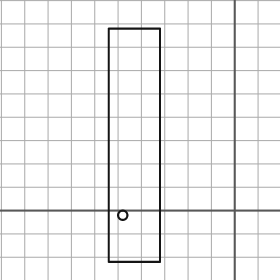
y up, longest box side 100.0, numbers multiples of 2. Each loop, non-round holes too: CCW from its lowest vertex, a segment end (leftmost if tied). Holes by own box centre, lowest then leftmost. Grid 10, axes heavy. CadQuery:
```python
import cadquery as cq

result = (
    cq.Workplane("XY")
    .moveTo(-54.0, -22.0)
    .lineTo(-32.0, -22.0)
    .lineTo(-32.0, 78.0)
    .lineTo(-54.0, 78.0)
    .close()
    .moveTo(-48.0, -2.0)
    .circle(2.0)
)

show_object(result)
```